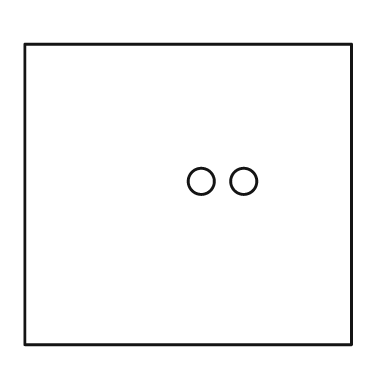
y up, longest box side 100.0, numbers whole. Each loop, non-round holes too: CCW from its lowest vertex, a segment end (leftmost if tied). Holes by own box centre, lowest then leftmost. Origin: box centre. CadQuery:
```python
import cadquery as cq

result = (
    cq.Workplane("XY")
    .moveTo(-50.0, -46.0)
    .lineTo(50.0, -46.0)
    .lineTo(50.0, 46.0)
    .lineTo(-50.0, 46.0)
    .close()
    .moveTo(4.0, 4.0)
    .circle(4.0)
    .moveTo(17.0, 4.0)
    .circle(4.0)
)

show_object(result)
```